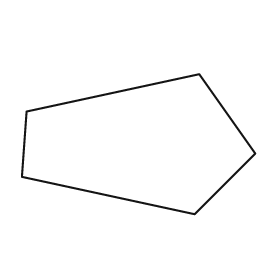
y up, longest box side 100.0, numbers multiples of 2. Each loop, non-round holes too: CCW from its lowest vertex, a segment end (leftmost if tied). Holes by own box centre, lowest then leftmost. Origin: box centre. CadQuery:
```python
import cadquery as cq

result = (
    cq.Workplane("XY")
    .moveTo(24.0, -30.0)
    .lineTo(50.0, -4.0)
    .lineTo(26.0, 30.0)
    .lineTo(-48.0, 14.0)
    .lineTo(-50.0, -14.0)
    .close()
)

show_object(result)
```